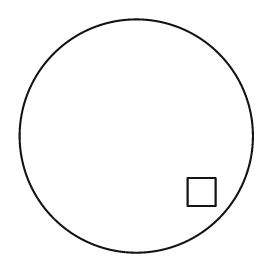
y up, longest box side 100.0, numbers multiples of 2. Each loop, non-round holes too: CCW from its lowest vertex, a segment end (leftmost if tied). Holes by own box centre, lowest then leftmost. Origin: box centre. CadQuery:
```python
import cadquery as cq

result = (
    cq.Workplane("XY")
    .moveTo(0.0, 0.0)
    .circle(50.0)
    .moveTo(22.0, -30.0)
    .lineTo(34.0, -30.0)
    .lineTo(34.0, -18.0)
    .lineTo(22.0, -18.0)
    .close()
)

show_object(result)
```